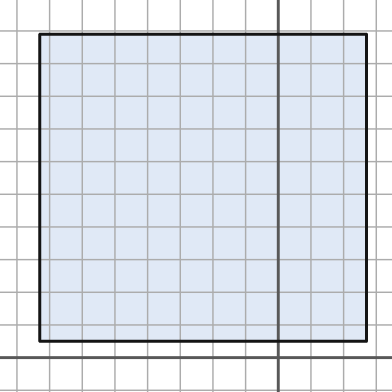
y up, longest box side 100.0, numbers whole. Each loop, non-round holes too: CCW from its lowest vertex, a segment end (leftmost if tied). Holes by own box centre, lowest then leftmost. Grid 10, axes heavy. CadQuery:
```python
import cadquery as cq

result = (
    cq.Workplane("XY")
    .moveTo(-73.0, 5.0)
    .lineTo(27.0, 5.0)
    .lineTo(27.0, 99.0)
    .lineTo(-73.0, 99.0)
    .close()
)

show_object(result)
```